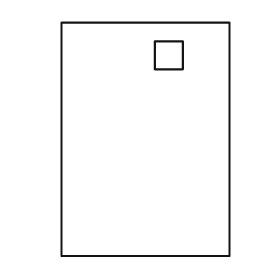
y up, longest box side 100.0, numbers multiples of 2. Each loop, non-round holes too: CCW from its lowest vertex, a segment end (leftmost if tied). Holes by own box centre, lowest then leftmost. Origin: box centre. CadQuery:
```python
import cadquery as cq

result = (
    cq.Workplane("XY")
    .moveTo(-36.0, -50.0)
    .lineTo(36.0, -50.0)
    .lineTo(36.0, 50.0)
    .lineTo(-36.0, 50.0)
    .close()
    .moveTo(4.0, 30.0)
    .lineTo(16.0, 30.0)
    .lineTo(16.0, 42.0)
    .lineTo(4.0, 42.0)
    .close()
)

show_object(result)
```